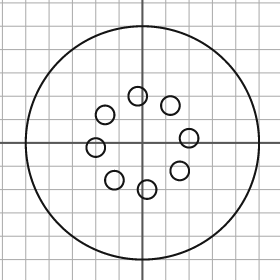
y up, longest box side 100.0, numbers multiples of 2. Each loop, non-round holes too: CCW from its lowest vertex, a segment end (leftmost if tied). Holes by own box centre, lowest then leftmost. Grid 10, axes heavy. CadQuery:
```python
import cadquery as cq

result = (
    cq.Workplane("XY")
    .moveTo(0.0, 0.0)
    .circle(50.0)
    .moveTo(2.0, -20.0)
    .circle(4.0)
    .moveTo(-12.0, -16.0)
    .circle(4.0)
    .moveTo(16.0, -12.0)
    .circle(4.0)
    .moveTo(-20.0, -2.0)
    .circle(4.0)
    .moveTo(20.0, 2.0)
    .circle(4.0)
    .moveTo(-16.0, 12.0)
    .circle(4.0)
    .moveTo(12.0, 16.0)
    .circle(4.0)
    .moveTo(-2.0, 20.0)
    .circle(4.0)
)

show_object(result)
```